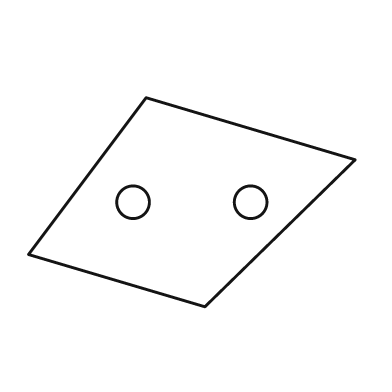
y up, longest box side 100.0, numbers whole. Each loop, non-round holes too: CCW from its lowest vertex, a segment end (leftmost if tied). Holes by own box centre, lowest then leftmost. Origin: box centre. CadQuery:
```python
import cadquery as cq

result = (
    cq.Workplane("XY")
    .moveTo(4.0, -32.0)
    .lineTo(50.0, 13.0)
    .lineTo(-14.0, 32.0)
    .lineTo(-50.0, -16.0)
    .close()
    .moveTo(-18.0, 0.0)
    .circle(5.0)
    .moveTo(18.0, 0.0)
    .circle(5.0)
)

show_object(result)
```